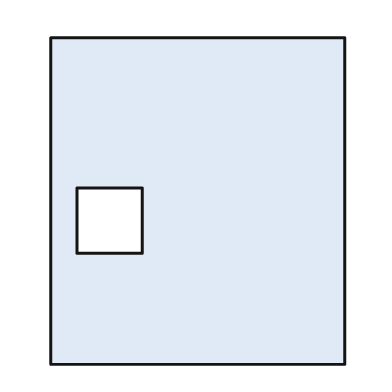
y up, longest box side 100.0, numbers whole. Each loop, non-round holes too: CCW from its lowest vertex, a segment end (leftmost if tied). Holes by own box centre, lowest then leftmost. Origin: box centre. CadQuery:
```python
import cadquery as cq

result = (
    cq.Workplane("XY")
    .moveTo(-45.0, -50.0)
    .lineTo(45.0, -50.0)
    .lineTo(45.0, 50.0)
    .lineTo(-45.0, 50.0)
    .close()
    .moveTo(-37.0, -16.0)
    .lineTo(-17.0, -16.0)
    .lineTo(-17.0, 4.0)
    .lineTo(-37.0, 4.0)
    .close()
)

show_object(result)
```